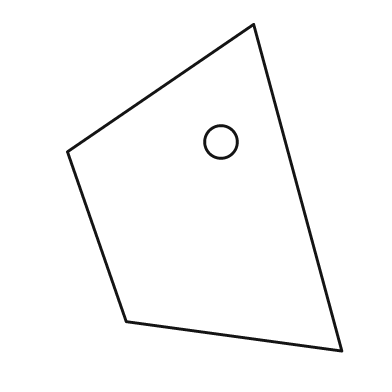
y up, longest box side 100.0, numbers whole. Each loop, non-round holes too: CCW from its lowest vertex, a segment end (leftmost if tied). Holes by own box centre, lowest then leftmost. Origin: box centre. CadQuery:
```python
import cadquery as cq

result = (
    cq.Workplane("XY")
    .moveTo(42.0, -50.0)
    .lineTo(15.0, 50.0)
    .lineTo(-42.0, 11.0)
    .lineTo(-24.0, -41.0)
    .close()
    .moveTo(5.0, 14.0)
    .circle(5.0)
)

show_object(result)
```